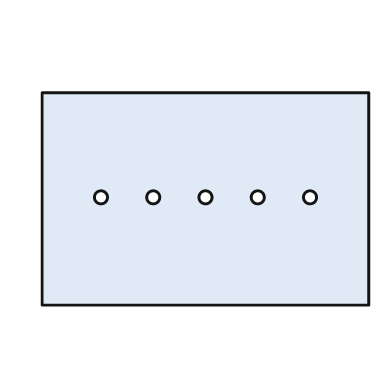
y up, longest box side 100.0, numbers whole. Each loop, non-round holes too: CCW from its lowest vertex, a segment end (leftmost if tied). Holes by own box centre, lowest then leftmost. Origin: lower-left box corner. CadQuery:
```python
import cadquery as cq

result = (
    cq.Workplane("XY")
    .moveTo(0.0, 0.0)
    .lineTo(100.0, 0.0)
    .lineTo(100.0, 65.0)
    .lineTo(0.0, 65.0)
    .close()
    .moveTo(18.0, 33.0)
    .circle(2.0)
    .moveTo(34.0, 33.0)
    .circle(2.0)
    .moveTo(50.0, 33.0)
    .circle(2.0)
    .moveTo(66.0, 33.0)
    .circle(2.0)
    .moveTo(82.0, 33.0)
    .circle(2.0)
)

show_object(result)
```